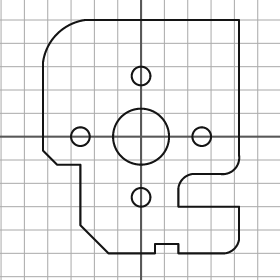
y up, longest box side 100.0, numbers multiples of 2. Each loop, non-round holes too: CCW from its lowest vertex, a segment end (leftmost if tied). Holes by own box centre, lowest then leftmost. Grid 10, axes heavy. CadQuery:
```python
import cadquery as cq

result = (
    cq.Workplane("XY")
    .moveTo(-14.0, -50.0)
    .lineTo(6.0, -50.0)
    .lineTo(6.0, -46.0)
    .lineTo(16.0, -46.0)
    .lineTo(16.0, -50.0)
    .lineTo(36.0, -50.0)
    .threePointArc((40.0, -48.0), (42.0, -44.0))
    .lineTo(42.0, -30.0)
    .lineTo(16.0, -30.0)
    .lineTo(16.0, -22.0)
    .threePointArc((18.0, -18.0), (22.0, -16.0))
    .lineTo(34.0, -16.0)
    .threePointArc((40.0, -14.0), (42.0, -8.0))
    .lineTo(42.0, 50.0)
    .lineTo(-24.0, 50.0)
    .threePointArc((-36.0, 44.0), (-42.0, 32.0))
    .lineTo(-42.0, -6.0)
    .lineTo(-36.0, -12.0)
    .lineTo(-26.0, -12.0)
    .lineTo(-26.0, -38.0)
    .close()
    .moveTo(0.0, -26.0)
    .circle(4.0)
    .moveTo(-26.0, 0.0)
    .circle(4.0)
    .moveTo(0.0, 0.0)
    .circle(12.0)
    .moveTo(26.0, 0.0)
    .circle(4.0)
    .moveTo(0.0, 26.0)
    .circle(4.0)
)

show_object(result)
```